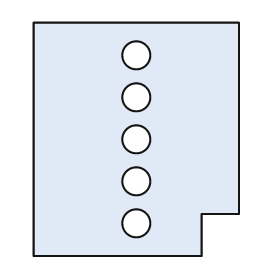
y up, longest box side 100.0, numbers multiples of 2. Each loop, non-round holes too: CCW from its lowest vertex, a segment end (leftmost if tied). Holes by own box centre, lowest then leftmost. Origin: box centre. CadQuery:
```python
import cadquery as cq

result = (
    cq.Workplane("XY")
    .moveTo(-44.0, -50.0)
    .lineTo(28.0, -50.0)
    .lineTo(28.0, -32.0)
    .lineTo(44.0, -32.0)
    .lineTo(44.0, 50.0)
    .lineTo(-44.0, 50.0)
    .close()
    .moveTo(0.0, -36.0)
    .circle(6.0)
    .moveTo(0.0, -18.0)
    .circle(6.0)
    .moveTo(0.0, 0.0)
    .circle(6.0)
    .moveTo(0.0, 18.0)
    .circle(6.0)
    .moveTo(0.0, 36.0)
    .circle(6.0)
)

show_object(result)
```